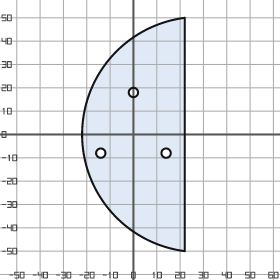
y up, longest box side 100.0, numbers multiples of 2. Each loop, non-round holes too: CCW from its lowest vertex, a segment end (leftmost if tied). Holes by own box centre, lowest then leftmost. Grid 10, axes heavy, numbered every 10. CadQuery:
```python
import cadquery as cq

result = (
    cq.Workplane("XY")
    .moveTo(22.0, -50.0)
    .lineTo(22.0, 50.0)
    .threePointArc((-22.0, 0.0), (22.0, -50.0))
    .close()
    .moveTo(-14.0, -8.0)
    .circle(2.0)
    .moveTo(14.0, -8.0)
    .circle(2.0)
    .moveTo(0.0, 18.0)
    .circle(2.0)
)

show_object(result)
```